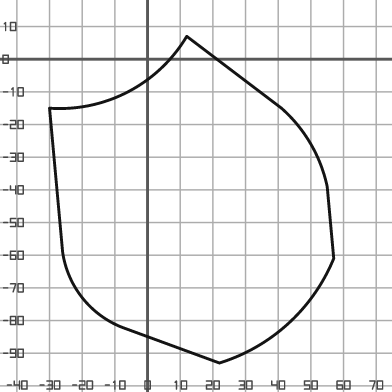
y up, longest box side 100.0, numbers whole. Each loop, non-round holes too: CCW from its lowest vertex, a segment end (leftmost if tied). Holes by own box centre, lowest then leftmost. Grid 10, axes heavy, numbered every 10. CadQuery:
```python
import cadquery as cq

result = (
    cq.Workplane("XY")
    .moveTo(22.0, -93.0)
    .threePointArc((43.0, -81.0), (57.0, -61.0))
    .lineTo(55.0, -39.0)
    .threePointArc((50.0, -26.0), (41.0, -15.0))
    .lineTo(12.0, 7.0)
    .threePointArc((-6.0, -10.0), (-30.0, -15.0))
    .lineTo(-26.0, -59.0)
    .threePointArc((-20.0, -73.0), (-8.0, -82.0))
    .close()
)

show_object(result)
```